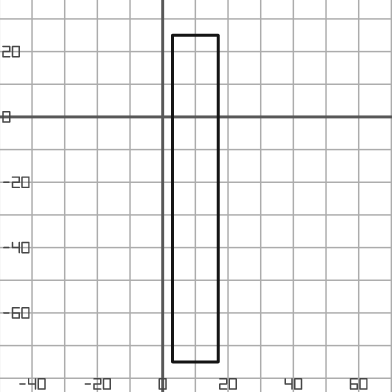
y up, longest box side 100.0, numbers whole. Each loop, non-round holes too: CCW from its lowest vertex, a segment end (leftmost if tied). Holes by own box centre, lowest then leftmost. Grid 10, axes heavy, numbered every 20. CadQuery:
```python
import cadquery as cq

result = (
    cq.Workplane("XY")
    .moveTo(3.0, -75.0)
    .lineTo(17.0, -75.0)
    .lineTo(17.0, 25.0)
    .lineTo(3.0, 25.0)
    .close()
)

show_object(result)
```